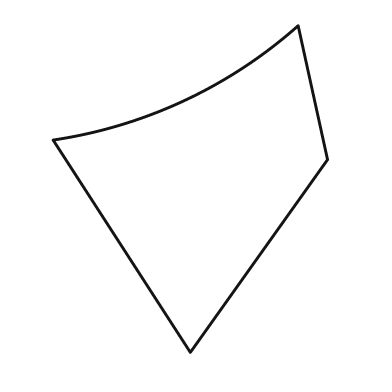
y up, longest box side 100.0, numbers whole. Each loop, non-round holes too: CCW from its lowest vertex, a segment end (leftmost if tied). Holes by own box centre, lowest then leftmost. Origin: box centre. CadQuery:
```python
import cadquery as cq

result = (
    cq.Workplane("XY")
    .moveTo(0.0, -50.0)
    .lineTo(42.0, 9.0)
    .lineTo(33.0, 50.0)
    .threePointArc((-2.0, 27.0), (-42.0, 15.0))
    .close()
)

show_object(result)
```